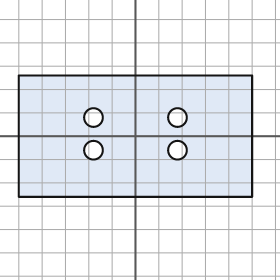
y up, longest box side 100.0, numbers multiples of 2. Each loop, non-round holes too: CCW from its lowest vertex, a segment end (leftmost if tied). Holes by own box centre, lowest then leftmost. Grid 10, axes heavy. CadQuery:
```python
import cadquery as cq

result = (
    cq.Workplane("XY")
    .moveTo(-50.0, -26.0)
    .lineTo(50.0, -26.0)
    .lineTo(50.0, 26.0)
    .lineTo(-50.0, 26.0)
    .close()
    .moveTo(-18.0, -6.0)
    .circle(4.0)
    .moveTo(18.0, -6.0)
    .circle(4.0)
    .moveTo(-18.0, 8.0)
    .circle(4.0)
    .moveTo(18.0, 8.0)
    .circle(4.0)
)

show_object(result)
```